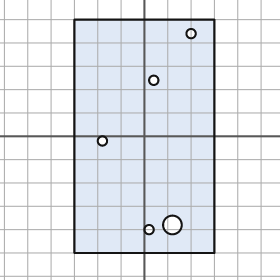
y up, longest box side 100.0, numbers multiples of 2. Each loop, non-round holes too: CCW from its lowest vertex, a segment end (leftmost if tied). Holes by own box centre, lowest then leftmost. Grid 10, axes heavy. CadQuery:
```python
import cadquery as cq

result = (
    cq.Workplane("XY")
    .moveTo(-30.0, -50.0)
    .lineTo(30.0, -50.0)
    .lineTo(30.0, 50.0)
    .lineTo(-30.0, 50.0)
    .close()
    .moveTo(2.0, -40.0)
    .circle(2.0)
    .moveTo(12.0, -38.0)
    .circle(4.0)
    .moveTo(-18.0, -2.0)
    .circle(2.0)
    .moveTo(4.0, 24.0)
    .circle(2.0)
    .moveTo(20.0, 44.0)
    .circle(2.0)
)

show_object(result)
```